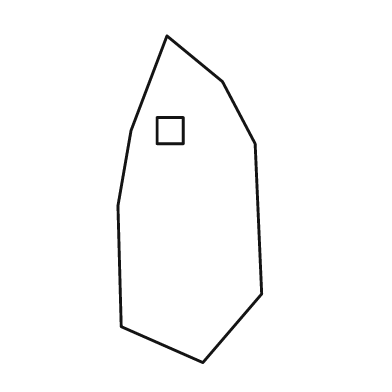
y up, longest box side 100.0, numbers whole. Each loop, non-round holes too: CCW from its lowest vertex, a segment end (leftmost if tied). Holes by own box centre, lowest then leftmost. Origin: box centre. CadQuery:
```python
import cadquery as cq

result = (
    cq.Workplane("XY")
    .moveTo(4.0, -50.0)
    .lineTo(22.0, -29.0)
    .lineTo(20.0, 17.0)
    .lineTo(10.0, 36.0)
    .lineTo(-7.0, 50.0)
    .lineTo(-18.0, 21.0)
    .lineTo(-22.0, -2.0)
    .lineTo(-21.0, -39.0)
    .close()
    .moveTo(-10.0, 17.0)
    .lineTo(-2.0, 17.0)
    .lineTo(-2.0, 25.0)
    .lineTo(-10.0, 25.0)
    .close()
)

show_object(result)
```